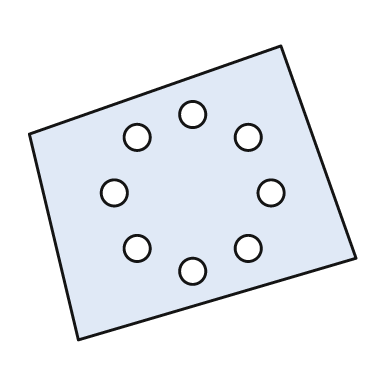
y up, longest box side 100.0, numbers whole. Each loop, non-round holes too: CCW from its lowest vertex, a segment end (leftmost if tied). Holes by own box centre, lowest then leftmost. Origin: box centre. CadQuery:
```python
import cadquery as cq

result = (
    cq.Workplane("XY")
    .moveTo(-35.0, -45.0)
    .lineTo(50.0, -20.0)
    .lineTo(27.0, 45.0)
    .lineTo(-50.0, 18.0)
    .close()
    .moveTo(0.0, -24.0)
    .circle(4.0)
    .moveTo(-17.0, -17.0)
    .circle(4.0)
    .moveTo(17.0, -17.0)
    .circle(4.0)
    .moveTo(-24.0, 0.0)
    .circle(4.0)
    .moveTo(24.0, 0.0)
    .circle(4.0)
    .moveTo(-17.0, 17.0)
    .circle(4.0)
    .moveTo(17.0, 17.0)
    .circle(4.0)
    .moveTo(0.0, 24.0)
    .circle(4.0)
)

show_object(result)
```